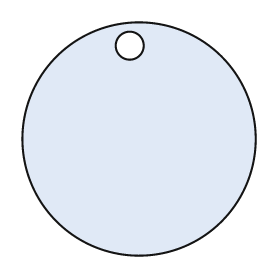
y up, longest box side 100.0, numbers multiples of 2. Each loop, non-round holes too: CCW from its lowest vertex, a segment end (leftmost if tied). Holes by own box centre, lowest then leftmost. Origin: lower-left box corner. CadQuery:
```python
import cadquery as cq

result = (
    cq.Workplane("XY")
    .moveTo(50.0, 50.0)
    .circle(50.0)
    .moveTo(46.0, 90.0)
    .circle(6.0)
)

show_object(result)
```